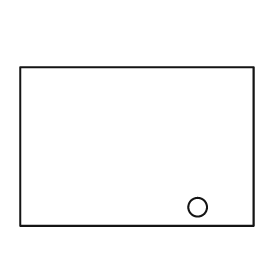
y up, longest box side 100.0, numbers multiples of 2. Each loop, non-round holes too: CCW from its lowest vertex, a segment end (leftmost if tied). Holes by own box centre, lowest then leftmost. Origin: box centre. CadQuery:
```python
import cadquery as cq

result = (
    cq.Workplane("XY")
    .moveTo(-50.0, -34.0)
    .lineTo(50.0, -34.0)
    .lineTo(50.0, 34.0)
    .lineTo(-50.0, 34.0)
    .close()
    .moveTo(26.0, -26.0)
    .circle(4.0)
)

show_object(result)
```